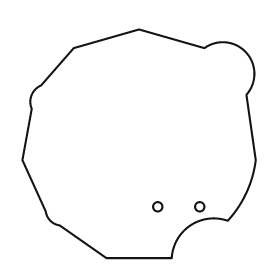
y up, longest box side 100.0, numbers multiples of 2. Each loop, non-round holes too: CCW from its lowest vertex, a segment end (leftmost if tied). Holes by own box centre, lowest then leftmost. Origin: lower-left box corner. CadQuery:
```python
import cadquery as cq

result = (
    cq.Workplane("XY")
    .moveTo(36.0, 0.0)
    .lineTo(64.0, 0.0)
    .threePointArc((72.0, 14.0), (88.0, 16.0))
    .threePointArc((96.0, 28.0), (100.0, 42.0))
    .lineTo(96.0, 70.0)
    .threePointArc((96.0, 88.0), (78.0, 90.0))
    .lineTo(50.0, 98.0)
    .lineTo(22.0, 90.0)
    .lineTo(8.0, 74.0)
    .threePointArc((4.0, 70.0), (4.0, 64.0))
    .lineTo(0.0, 42.0)
    .lineTo(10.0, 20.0)
    .threePointArc((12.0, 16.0), (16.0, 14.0))
    .close()
    .moveTo(58.0, 22.0)
    .circle(2.0)
    .moveTo(76.0, 22.0)
    .circle(2.0)
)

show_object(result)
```